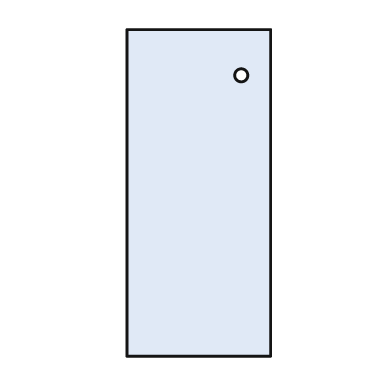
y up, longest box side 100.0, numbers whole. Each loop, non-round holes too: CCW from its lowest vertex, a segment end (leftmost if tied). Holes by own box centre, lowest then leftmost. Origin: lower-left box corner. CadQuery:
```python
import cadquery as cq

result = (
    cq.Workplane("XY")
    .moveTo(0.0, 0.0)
    .lineTo(44.0, 0.0)
    .lineTo(44.0, 100.0)
    .lineTo(0.0, 100.0)
    .close()
    .moveTo(35.0, 86.0)
    .circle(2.0)
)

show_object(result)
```